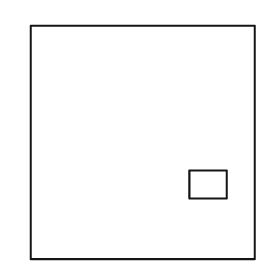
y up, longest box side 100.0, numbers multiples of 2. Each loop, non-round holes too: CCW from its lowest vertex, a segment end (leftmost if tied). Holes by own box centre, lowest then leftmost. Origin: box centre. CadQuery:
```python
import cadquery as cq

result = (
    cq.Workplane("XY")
    .moveTo(-48.0, -50.0)
    .lineTo(48.0, -50.0)
    .lineTo(48.0, 50.0)
    .lineTo(-48.0, 50.0)
    .close()
    .moveTo(20.0, -24.0)
    .lineTo(36.0, -24.0)
    .lineTo(36.0, -12.0)
    .lineTo(20.0, -12.0)
    .close()
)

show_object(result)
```